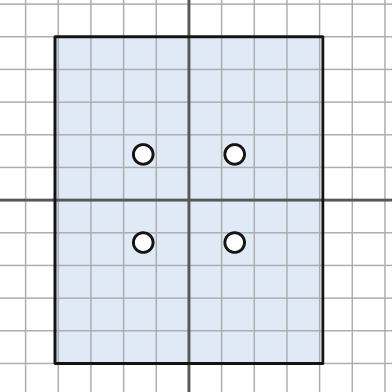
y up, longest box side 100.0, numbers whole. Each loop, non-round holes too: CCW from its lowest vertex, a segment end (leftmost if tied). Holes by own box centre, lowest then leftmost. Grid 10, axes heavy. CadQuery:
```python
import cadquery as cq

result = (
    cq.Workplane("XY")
    .moveTo(-41.0, -50.0)
    .lineTo(41.0, -50.0)
    .lineTo(41.0, 50.0)
    .lineTo(-41.0, 50.0)
    .close()
    .moveTo(-14.0, -13.0)
    .circle(3.0)
    .moveTo(14.0, -13.0)
    .circle(3.0)
    .moveTo(-14.0, 14.0)
    .circle(3.0)
    .moveTo(14.0, 14.0)
    .circle(3.0)
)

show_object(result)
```